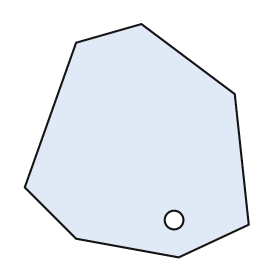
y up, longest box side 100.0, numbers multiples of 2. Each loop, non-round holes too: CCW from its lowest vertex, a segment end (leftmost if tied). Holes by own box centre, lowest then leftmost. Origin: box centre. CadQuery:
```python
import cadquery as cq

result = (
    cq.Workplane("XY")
    .moveTo(18.0, -50.0)
    .lineTo(48.0, -36.0)
    .lineTo(42.0, 20.0)
    .lineTo(2.0, 50.0)
    .lineTo(-26.0, 42.0)
    .lineTo(-48.0, -20.0)
    .lineTo(-26.0, -42.0)
    .close()
    .moveTo(16.0, -34.0)
    .circle(4.0)
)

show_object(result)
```